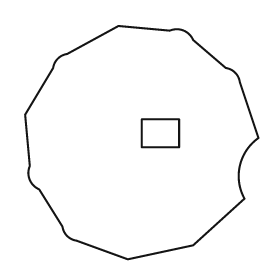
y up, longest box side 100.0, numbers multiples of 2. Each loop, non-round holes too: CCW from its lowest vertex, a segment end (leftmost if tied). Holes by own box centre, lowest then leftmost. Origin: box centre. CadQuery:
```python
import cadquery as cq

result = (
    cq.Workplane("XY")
    .moveTo(-6.0, -50.0)
    .lineTo(22.0, -44.0)
    .lineTo(44.0, -24.0)
    .threePointArc((42.0, -10.0), (50.0, 2.0))
    .lineTo(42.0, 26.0)
    .threePointArc((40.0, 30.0), (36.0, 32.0))
    .lineTo(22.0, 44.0)
    .threePointArc((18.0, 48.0), (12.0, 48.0))
    .lineTo(-10.0, 50.0)
    .lineTo(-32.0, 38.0)
    .threePointArc((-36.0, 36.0), (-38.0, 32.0))
    .lineTo(-50.0, 12.0)
    .lineTo(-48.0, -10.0)
    .threePointArc((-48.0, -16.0), (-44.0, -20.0))
    .lineTo(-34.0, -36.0)
    .threePointArc((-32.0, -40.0), (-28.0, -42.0))
    .close()
    .moveTo(0.0, -2.0)
    .lineTo(16.0, -2.0)
    .lineTo(16.0, 10.0)
    .lineTo(0.0, 10.0)
    .close()
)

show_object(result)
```